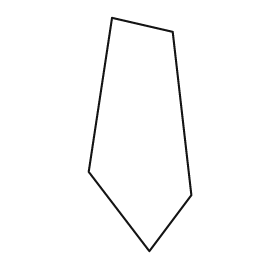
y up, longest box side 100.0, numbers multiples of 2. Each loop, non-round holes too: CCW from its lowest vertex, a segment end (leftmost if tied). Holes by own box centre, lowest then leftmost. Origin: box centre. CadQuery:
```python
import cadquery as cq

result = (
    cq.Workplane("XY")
    .moveTo(4.0, -50.0)
    .lineTo(22.0, -26.0)
    .lineTo(14.0, 44.0)
    .lineTo(-12.0, 50.0)
    .lineTo(-22.0, -16.0)
    .close()
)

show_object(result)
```